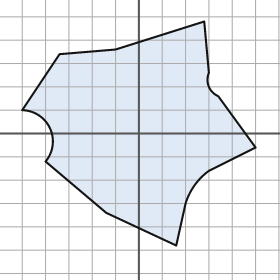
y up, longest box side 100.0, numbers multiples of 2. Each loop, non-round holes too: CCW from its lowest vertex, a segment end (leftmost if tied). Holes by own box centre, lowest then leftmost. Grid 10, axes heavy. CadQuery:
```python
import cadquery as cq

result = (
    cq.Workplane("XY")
    .moveTo(16.0, -48.0)
    .lineTo(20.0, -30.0)
    .threePointArc((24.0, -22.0), (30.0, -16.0))
    .lineTo(50.0, -6.0)
    .lineTo(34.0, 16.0)
    .threePointArc((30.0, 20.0), (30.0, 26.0))
    .lineTo(28.0, 48.0)
    .lineTo(-10.0, 36.0)
    .lineTo(-34.0, 34.0)
    .lineTo(-50.0, 10.0)
    .threePointArc((-38.0, 2.0), (-40.0, -12.0))
    .lineTo(-14.0, -34.0)
    .close()
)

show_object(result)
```